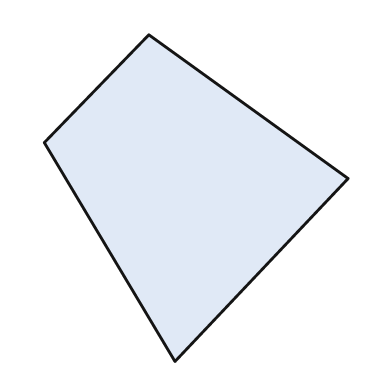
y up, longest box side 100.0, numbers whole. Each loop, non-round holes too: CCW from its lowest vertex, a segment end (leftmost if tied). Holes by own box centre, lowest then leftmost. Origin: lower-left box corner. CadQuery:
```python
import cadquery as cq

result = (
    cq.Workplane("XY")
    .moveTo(40.0, 0.0)
    .lineTo(93.0, 56.0)
    .lineTo(32.0, 100.0)
    .lineTo(0.0, 67.0)
    .close()
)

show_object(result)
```